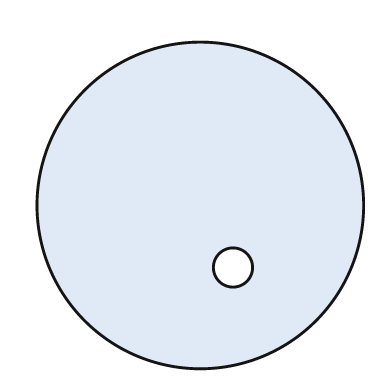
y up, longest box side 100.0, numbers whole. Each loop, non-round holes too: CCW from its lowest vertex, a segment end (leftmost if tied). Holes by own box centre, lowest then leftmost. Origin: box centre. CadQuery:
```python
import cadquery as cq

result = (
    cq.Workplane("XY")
    .moveTo(0.0, 0.0)
    .circle(50.0)
    .moveTo(10.0, -19.0)
    .circle(6.0)
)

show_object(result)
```